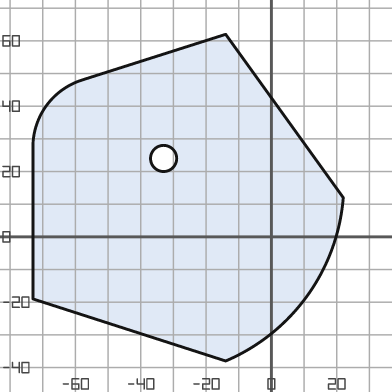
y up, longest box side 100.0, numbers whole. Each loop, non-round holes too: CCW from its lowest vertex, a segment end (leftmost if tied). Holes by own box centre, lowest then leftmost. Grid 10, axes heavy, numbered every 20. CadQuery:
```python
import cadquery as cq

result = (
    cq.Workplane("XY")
    .moveTo(-14.0, -38.0)
    .threePointArc((11.0, -18.0), (22.0, 12.0))
    .lineTo(-14.0, 62.0)
    .lineTo(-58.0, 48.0)
    .threePointArc((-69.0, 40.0), (-73.0, 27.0))
    .lineTo(-73.0, -19.0)
    .close()
    .moveTo(-33.0, 24.0)
    .circle(4.0)
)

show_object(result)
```